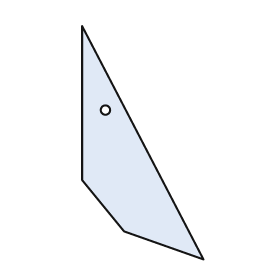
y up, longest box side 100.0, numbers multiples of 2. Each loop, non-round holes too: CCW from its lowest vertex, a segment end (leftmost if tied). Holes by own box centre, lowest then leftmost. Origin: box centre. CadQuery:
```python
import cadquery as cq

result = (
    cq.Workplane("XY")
    .moveTo(26.0, -50.0)
    .lineTo(-26.0, 50.0)
    .lineTo(-26.0, -16.0)
    .lineTo(-8.0, -38.0)
    .close()
    .moveTo(-16.0, 14.0)
    .circle(2.0)
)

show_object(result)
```